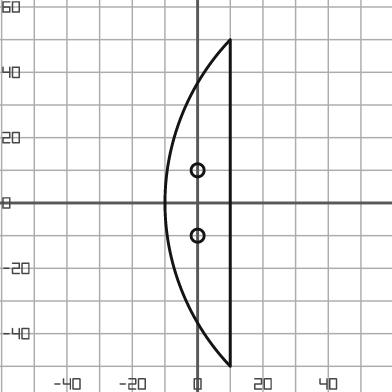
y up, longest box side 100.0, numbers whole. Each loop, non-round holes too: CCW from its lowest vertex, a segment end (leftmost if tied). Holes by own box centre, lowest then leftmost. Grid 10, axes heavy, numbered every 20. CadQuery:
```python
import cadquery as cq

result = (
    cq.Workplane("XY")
    .moveTo(10.0, -50.0)
    .lineTo(10.0, 50.0)
    .threePointArc((-10.0, 0.0), (10.0, -50.0))
    .close()
    .moveTo(0.0, -10.0)
    .circle(2.0)
    .moveTo(0.0, 10.0)
    .circle(2.0)
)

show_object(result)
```